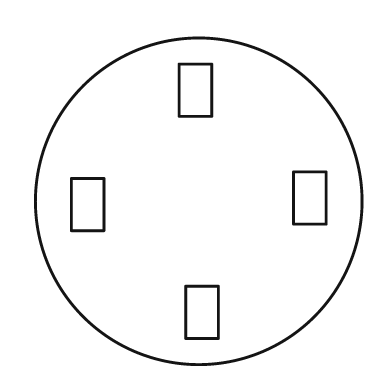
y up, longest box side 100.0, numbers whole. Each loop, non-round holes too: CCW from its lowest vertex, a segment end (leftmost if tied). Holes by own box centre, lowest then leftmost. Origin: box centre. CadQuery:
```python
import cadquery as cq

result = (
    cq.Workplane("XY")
    .moveTo(0.0, 0.0)
    .circle(50.0)
    .moveTo(-4.0, -42.0)
    .lineTo(6.0, -42.0)
    .lineTo(6.0, -26.0)
    .lineTo(-4.0, -26.0)
    .close()
    .moveTo(-39.0, -9.0)
    .lineTo(-29.0, -9.0)
    .lineTo(-29.0, 7.0)
    .lineTo(-39.0, 7.0)
    .close()
    .moveTo(29.0, -7.0)
    .lineTo(39.0, -7.0)
    .lineTo(39.0, 9.0)
    .lineTo(29.0, 9.0)
    .close()
    .moveTo(-6.0, 26.0)
    .lineTo(4.0, 26.0)
    .lineTo(4.0, 42.0)
    .lineTo(-6.0, 42.0)
    .close()
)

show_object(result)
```